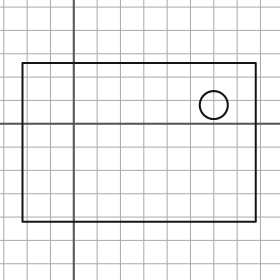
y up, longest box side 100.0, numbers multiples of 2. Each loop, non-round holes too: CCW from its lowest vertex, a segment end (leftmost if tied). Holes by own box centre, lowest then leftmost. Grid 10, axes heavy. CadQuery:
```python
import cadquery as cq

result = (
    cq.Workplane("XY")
    .moveTo(-22.0, -42.0)
    .lineTo(78.0, -42.0)
    .lineTo(78.0, 26.0)
    .lineTo(-22.0, 26.0)
    .close()
    .moveTo(60.0, 8.0)
    .circle(6.0)
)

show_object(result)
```